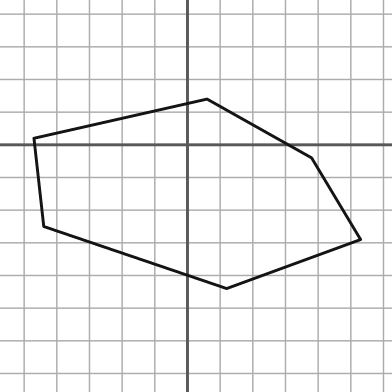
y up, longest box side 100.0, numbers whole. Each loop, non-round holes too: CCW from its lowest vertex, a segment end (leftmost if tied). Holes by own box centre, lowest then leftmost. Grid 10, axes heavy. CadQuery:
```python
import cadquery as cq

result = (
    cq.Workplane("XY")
    .moveTo(12.0, -44.0)
    .lineTo(53.0, -29.0)
    .lineTo(38.0, -4.0)
    .lineTo(6.0, 14.0)
    .lineTo(-47.0, 2.0)
    .lineTo(-44.0, -25.0)
    .close()
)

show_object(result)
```